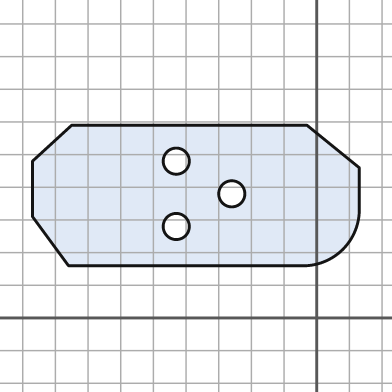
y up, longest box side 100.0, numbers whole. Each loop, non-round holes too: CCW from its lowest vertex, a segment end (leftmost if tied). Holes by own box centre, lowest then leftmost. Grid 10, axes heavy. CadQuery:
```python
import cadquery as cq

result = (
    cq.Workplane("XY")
    .moveTo(-76.0, 16.0)
    .lineTo(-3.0, 16.0)
    .threePointArc((8.0, 21.0), (13.0, 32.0))
    .lineTo(13.0, 46.0)
    .lineTo(-3.0, 59.0)
    .lineTo(-75.0, 59.0)
    .lineTo(-87.0, 48.0)
    .lineTo(-87.0, 31.0)
    .close()
    .moveTo(-43.0, 28.0)
    .circle(4.0)
    .moveTo(-26.0, 38.0)
    .circle(4.0)
    .moveTo(-43.0, 48.0)
    .circle(4.0)
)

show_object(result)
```